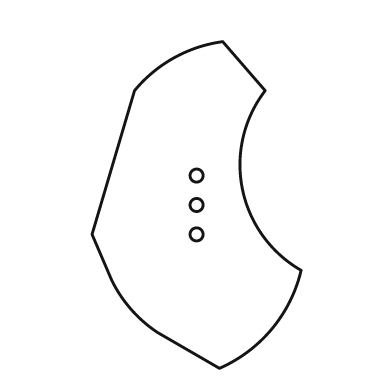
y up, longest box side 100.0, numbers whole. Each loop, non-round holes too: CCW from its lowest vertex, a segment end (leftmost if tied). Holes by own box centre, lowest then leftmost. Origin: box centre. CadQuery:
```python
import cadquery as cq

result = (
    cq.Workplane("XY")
    .moveTo(7.0, -50.0)
    .threePointArc((23.0, -38.0), (32.0, -20.0))
    .threePointArc((14.0, 5.0), (21.0, 35.0))
    .lineTo(8.0, 50.0)
    .threePointArc((-7.0, 45.0), (-19.0, 35.0))
    .lineTo(-32.0, -9.0)
    .lineTo(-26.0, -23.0)
    .threePointArc((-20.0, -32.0), (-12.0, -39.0))
    .close()
    .moveTo(0.0, -9.0)
    .circle(2.0)
    .moveTo(0.0, 0.0)
    .circle(2.0)
    .moveTo(0.0, 9.0)
    .circle(2.0)
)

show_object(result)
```